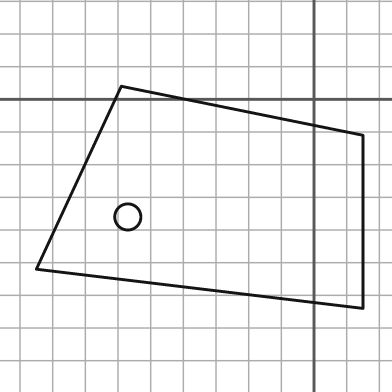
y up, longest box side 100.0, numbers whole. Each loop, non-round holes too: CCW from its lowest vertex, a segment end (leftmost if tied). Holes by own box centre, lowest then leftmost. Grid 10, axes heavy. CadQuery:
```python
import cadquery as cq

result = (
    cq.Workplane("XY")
    .moveTo(15.0, -64.0)
    .lineTo(15.0, -11.0)
    .lineTo(-59.0, 4.0)
    .lineTo(-85.0, -52.0)
    .close()
    .moveTo(-57.0, -36.0)
    .circle(4.0)
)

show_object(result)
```